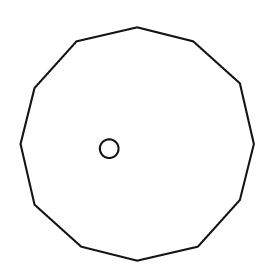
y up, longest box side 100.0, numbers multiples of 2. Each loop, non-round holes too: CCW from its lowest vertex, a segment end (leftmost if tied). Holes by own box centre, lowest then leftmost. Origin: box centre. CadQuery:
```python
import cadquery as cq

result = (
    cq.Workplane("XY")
    .moveTo(0.0, -50.0)
    .lineTo(26.0, -44.0)
    .lineTo(44.0, -24.0)
    .lineTo(50.0, 0.0)
    .lineTo(44.0, 26.0)
    .lineTo(24.0, 44.0)
    .lineTo(0.0, 50.0)
    .lineTo(-26.0, 44.0)
    .lineTo(-44.0, 24.0)
    .lineTo(-50.0, 0.0)
    .lineTo(-44.0, -26.0)
    .lineTo(-24.0, -44.0)
    .close()
    .moveTo(-12.0, -2.0)
    .circle(4.0)
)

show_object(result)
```